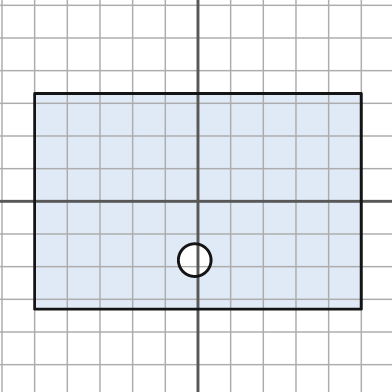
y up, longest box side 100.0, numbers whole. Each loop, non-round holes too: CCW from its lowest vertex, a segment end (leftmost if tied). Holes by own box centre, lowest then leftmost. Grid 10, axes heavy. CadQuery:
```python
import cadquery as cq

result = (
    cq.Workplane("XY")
    .moveTo(-50.0, -33.0)
    .lineTo(50.0, -33.0)
    .lineTo(50.0, 33.0)
    .lineTo(-50.0, 33.0)
    .close()
    .moveTo(-1.0, -18.0)
    .circle(5.0)
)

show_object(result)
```